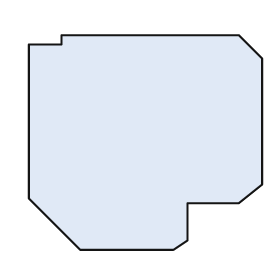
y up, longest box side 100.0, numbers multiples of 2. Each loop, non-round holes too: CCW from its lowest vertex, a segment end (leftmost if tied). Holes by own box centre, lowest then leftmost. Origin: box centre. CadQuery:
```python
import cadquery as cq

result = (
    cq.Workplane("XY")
    .moveTo(-28.0, -46.0)
    .lineTo(12.0, -46.0)
    .lineTo(18.0, -42.0)
    .lineTo(18.0, -26.0)
    .lineTo(40.0, -26.0)
    .lineTo(50.0, -18.0)
    .lineTo(50.0, 36.0)
    .lineTo(40.0, 46.0)
    .lineTo(-36.0, 46.0)
    .lineTo(-36.0, 42.0)
    .lineTo(-50.0, 42.0)
    .lineTo(-50.0, -24.0)
    .close()
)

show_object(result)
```